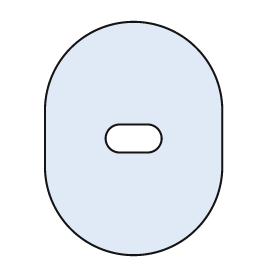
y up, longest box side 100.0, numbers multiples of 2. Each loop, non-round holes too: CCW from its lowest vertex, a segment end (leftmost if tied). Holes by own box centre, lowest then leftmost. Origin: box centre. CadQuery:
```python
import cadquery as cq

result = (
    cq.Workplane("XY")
    .moveTo(-38.0, -12.0)
    .threePointArc((0.0, -50.0), (38.0, -12.0))
    .lineTo(38.0, 12.0)
    .threePointArc((0.0, 50.0), (-38.0, 12.0))
    .close()
    .moveTo(-6.0, -6.0)
    .lineTo(6.0, -6.0)
    .threePointArc((12.0, 0.0), (6.0, 6.0))
    .lineTo(-6.0, 6.0)
    .threePointArc((-12.0, 0.0), (-6.0, -6.0))
    .close()
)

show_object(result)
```